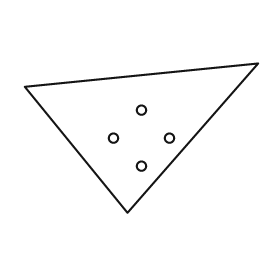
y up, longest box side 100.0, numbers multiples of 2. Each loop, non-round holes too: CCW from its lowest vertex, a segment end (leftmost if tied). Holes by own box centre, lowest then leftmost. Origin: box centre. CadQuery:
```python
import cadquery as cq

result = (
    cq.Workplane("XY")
    .moveTo(-6.0, -32.0)
    .lineTo(50.0, 32.0)
    .lineTo(-50.0, 22.0)
    .close()
    .moveTo(0.0, -12.0)
    .circle(2.0)
    .moveTo(-12.0, 0.0)
    .circle(2.0)
    .moveTo(12.0, 0.0)
    .circle(2.0)
    .moveTo(0.0, 12.0)
    .circle(2.0)
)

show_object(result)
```